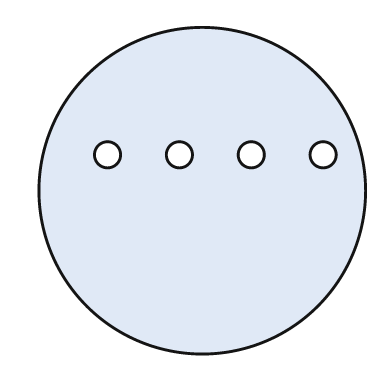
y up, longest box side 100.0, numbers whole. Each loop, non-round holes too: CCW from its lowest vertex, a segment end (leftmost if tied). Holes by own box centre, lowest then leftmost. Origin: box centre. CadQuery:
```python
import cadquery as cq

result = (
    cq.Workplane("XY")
    .moveTo(0.0, 0.0)
    .circle(50.0)
    .moveTo(-29.0, 11.0)
    .circle(4.0)
    .moveTo(-7.0, 11.0)
    .circle(4.0)
    .moveTo(15.0, 11.0)
    .circle(4.0)
    .moveTo(37.0, 11.0)
    .circle(4.0)
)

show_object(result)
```